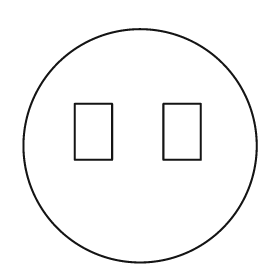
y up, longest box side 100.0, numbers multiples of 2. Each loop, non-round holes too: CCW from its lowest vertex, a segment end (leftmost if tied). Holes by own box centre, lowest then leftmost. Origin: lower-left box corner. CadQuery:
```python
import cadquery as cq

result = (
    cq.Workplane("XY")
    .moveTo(50.0, 50.0)
    .circle(50.0)
    .moveTo(22.0, 44.0)
    .lineTo(38.0, 44.0)
    .lineTo(38.0, 68.0)
    .lineTo(22.0, 68.0)
    .close()
    .moveTo(60.0, 44.0)
    .lineTo(76.0, 44.0)
    .lineTo(76.0, 68.0)
    .lineTo(60.0, 68.0)
    .close()
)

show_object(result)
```